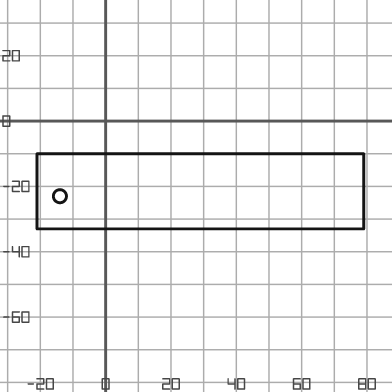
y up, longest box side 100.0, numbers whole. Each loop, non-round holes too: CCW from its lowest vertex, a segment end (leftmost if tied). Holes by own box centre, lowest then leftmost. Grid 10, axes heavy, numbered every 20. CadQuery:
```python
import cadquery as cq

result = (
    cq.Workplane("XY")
    .moveTo(-21.0, -33.0)
    .lineTo(79.0, -33.0)
    .lineTo(79.0, -10.0)
    .lineTo(-21.0, -10.0)
    .close()
    .moveTo(-14.0, -23.0)
    .circle(2.0)
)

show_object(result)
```